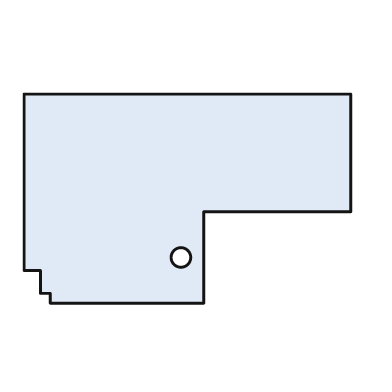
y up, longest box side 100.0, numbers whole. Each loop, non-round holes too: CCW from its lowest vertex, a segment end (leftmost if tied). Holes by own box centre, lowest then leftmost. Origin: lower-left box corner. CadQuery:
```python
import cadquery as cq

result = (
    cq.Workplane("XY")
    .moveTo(8.0, 0.0)
    .lineTo(55.0, 0.0)
    .lineTo(55.0, 28.0)
    .lineTo(100.0, 28.0)
    .lineTo(100.0, 64.0)
    .lineTo(0.0, 64.0)
    .lineTo(0.0, 10.0)
    .lineTo(5.0, 10.0)
    .lineTo(5.0, 3.0)
    .lineTo(8.0, 3.0)
    .close()
    .moveTo(48.0, 14.0)
    .circle(3.0)
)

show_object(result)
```